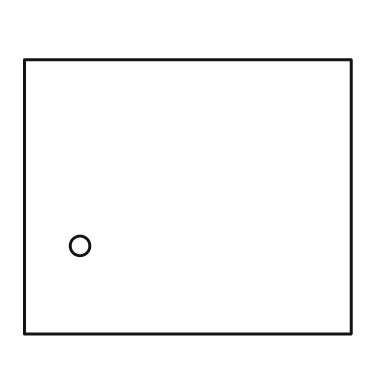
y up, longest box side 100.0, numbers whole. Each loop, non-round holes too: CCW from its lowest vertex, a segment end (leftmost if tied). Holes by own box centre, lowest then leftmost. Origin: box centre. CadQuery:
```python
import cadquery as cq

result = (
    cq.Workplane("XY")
    .moveTo(-50.0, -42.0)
    .lineTo(50.0, -42.0)
    .lineTo(50.0, 42.0)
    .lineTo(-50.0, 42.0)
    .close()
    .moveTo(-33.0, -15.0)
    .circle(3.0)
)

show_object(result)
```